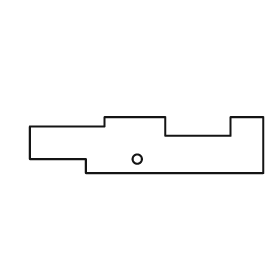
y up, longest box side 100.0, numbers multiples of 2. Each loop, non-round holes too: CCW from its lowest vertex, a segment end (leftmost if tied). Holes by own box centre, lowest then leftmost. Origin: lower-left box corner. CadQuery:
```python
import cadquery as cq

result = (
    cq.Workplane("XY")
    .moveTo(24.0, 0.0)
    .lineTo(100.0, 0.0)
    .lineTo(100.0, 24.0)
    .lineTo(86.0, 24.0)
    .lineTo(86.0, 16.0)
    .lineTo(58.0, 16.0)
    .lineTo(58.0, 24.0)
    .lineTo(32.0, 24.0)
    .lineTo(32.0, 20.0)
    .lineTo(0.0, 20.0)
    .lineTo(0.0, 6.0)
    .lineTo(24.0, 6.0)
    .close()
    .moveTo(46.0, 6.0)
    .circle(2.0)
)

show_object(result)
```